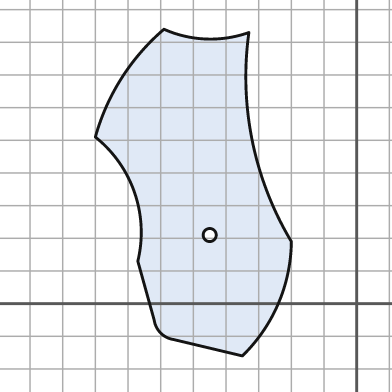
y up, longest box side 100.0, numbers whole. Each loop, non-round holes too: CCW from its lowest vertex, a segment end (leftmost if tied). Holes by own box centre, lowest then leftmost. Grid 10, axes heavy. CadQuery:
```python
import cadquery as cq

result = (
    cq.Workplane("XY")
    .moveTo(-35.0, -16.0)
    .threePointArc((-24.0, 0.0), (-20.0, 19.0))
    .threePointArc((-32.0, 50.0), (-33.0, 83.0))
    .threePointArc((-46.0, 81.0), (-59.0, 84.0))
    .threePointArc((-72.0, 69.0), (-80.0, 51.0))
    .threePointArc((-68.0, 34.0), (-67.0, 13.0))
    .lineTo(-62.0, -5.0)
    .threePointArc((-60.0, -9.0), (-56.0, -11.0))
    .close()
    .moveTo(-45.0, 21.0)
    .circle(2.0)
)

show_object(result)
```